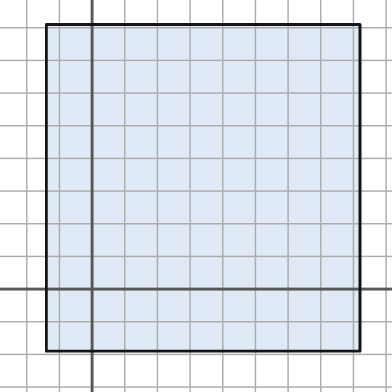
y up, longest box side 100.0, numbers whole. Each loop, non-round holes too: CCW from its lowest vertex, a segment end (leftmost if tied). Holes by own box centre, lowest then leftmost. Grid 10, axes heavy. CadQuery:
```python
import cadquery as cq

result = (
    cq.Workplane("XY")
    .moveTo(-14.0, -19.0)
    .lineTo(82.0, -19.0)
    .lineTo(82.0, 81.0)
    .lineTo(-14.0, 81.0)
    .close()
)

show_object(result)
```